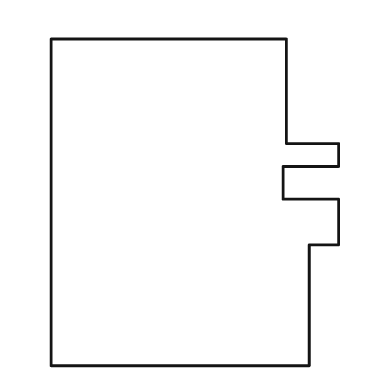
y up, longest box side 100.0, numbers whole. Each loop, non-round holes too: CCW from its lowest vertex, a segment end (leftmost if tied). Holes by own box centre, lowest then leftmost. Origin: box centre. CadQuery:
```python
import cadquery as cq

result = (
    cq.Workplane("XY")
    .moveTo(-44.0, -50.0)
    .lineTo(35.0, -50.0)
    .lineTo(35.0, -13.0)
    .lineTo(44.0, -13.0)
    .lineTo(44.0, 1.0)
    .lineTo(27.0, 1.0)
    .lineTo(27.0, 11.0)
    .lineTo(44.0, 11.0)
    .lineTo(44.0, 18.0)
    .lineTo(28.0, 18.0)
    .lineTo(28.0, 50.0)
    .lineTo(-44.0, 50.0)
    .close()
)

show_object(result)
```